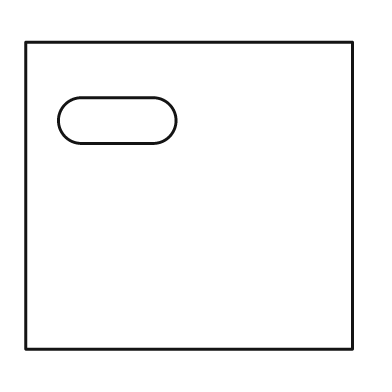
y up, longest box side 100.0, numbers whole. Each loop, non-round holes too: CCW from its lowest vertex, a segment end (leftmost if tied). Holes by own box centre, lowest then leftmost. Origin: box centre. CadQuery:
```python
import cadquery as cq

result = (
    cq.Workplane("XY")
    .moveTo(-50.0, -47.0)
    .lineTo(50.0, -47.0)
    .lineTo(50.0, 47.0)
    .lineTo(-50.0, 47.0)
    .close()
    .moveTo(-33.0, 16.0)
    .lineTo(-11.0, 16.0)
    .threePointArc((-4.0, 23.0), (-11.0, 30.0))
    .lineTo(-33.0, 30.0)
    .threePointArc((-40.0, 23.0), (-33.0, 16.0))
    .close()
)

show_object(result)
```